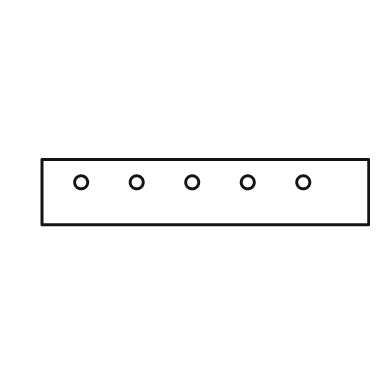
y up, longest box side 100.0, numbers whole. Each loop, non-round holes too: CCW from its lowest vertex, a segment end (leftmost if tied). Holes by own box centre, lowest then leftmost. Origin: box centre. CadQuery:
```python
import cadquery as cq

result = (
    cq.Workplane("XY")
    .moveTo(-50.0, -10.0)
    .lineTo(50.0, -10.0)
    .lineTo(50.0, 10.0)
    .lineTo(-50.0, 10.0)
    .close()
    .moveTo(-38.0, 3.0)
    .circle(2.0)
    .moveTo(-21.0, 3.0)
    .circle(2.0)
    .moveTo(-4.0, 3.0)
    .circle(2.0)
    .moveTo(13.0, 3.0)
    .circle(2.0)
    .moveTo(30.0, 3.0)
    .circle(2.0)
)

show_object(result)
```